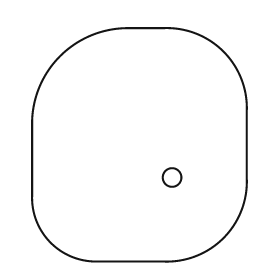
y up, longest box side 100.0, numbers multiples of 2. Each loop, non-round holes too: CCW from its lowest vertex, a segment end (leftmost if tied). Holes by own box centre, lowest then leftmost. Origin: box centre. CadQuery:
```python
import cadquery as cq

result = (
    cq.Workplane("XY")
    .moveTo(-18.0, -50.0)
    .lineTo(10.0, -50.0)
    .threePointArc((36.0, -40.0), (46.0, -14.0))
    .lineTo(46.0, 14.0)
    .threePointArc((36.0, 40.0), (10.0, 50.0))
    .lineTo(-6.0, 50.0)
    .threePointArc((-34.0, 38.0), (-46.0, 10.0))
    .lineTo(-46.0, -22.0)
    .threePointArc((-38.0, -42.0), (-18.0, -50.0))
    .close()
    .moveTo(14.0, -14.0)
    .circle(4.0)
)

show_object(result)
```